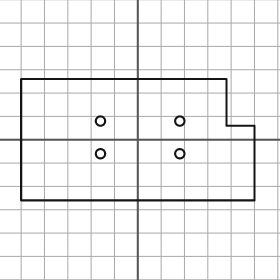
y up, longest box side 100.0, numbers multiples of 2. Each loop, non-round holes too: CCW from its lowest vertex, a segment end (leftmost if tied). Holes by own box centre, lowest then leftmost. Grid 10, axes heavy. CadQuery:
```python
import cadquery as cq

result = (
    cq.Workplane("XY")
    .moveTo(-50.0, -26.0)
    .lineTo(50.0, -26.0)
    .lineTo(50.0, 6.0)
    .lineTo(38.0, 6.0)
    .lineTo(38.0, 26.0)
    .lineTo(-50.0, 26.0)
    .close()
    .moveTo(-16.0, -6.0)
    .circle(2.0)
    .moveTo(18.0, -6.0)
    .circle(2.0)
    .moveTo(-16.0, 8.0)
    .circle(2.0)
    .moveTo(18.0, 8.0)
    .circle(2.0)
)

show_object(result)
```